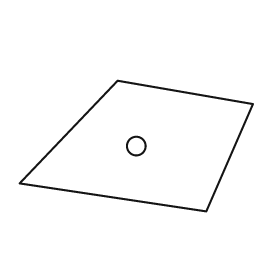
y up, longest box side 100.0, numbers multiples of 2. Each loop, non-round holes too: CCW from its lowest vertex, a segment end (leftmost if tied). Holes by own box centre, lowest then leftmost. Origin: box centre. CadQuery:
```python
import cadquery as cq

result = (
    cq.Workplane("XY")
    .moveTo(30.0, -28.0)
    .lineTo(50.0, 18.0)
    .lineTo(-8.0, 28.0)
    .lineTo(-50.0, -16.0)
    .close()
    .moveTo(0.0, 0.0)
    .circle(4.0)
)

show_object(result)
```